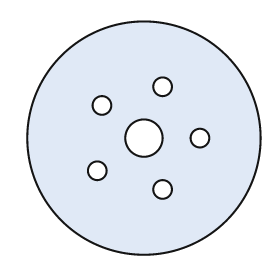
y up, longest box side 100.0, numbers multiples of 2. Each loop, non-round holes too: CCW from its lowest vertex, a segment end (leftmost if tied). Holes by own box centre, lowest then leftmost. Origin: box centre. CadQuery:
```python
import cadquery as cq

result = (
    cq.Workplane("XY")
    .moveTo(0.0, 0.0)
    .circle(50.0)
    .moveTo(8.0, -22.0)
    .circle(4.0)
    .moveTo(-20.0, -14.0)
    .circle(4.0)
    .moveTo(0.0, 0.0)
    .circle(8.0)
    .moveTo(24.0, 0.0)
    .circle(4.0)
    .moveTo(-18.0, 14.0)
    .circle(4.0)
    .moveTo(8.0, 22.0)
    .circle(4.0)
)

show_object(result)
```